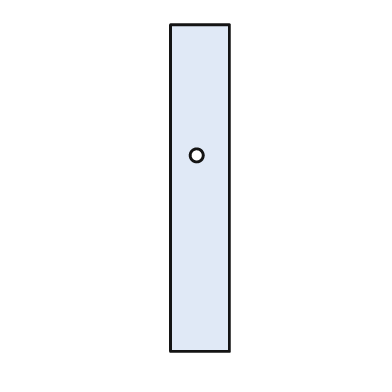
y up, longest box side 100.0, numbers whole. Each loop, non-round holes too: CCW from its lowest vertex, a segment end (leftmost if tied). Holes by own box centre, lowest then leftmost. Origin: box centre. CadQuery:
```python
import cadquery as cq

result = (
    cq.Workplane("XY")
    .moveTo(-9.0, -50.0)
    .lineTo(9.0, -50.0)
    .lineTo(9.0, 50.0)
    .lineTo(-9.0, 50.0)
    .close()
    .moveTo(-1.0, 10.0)
    .circle(2.0)
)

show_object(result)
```